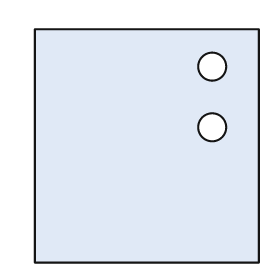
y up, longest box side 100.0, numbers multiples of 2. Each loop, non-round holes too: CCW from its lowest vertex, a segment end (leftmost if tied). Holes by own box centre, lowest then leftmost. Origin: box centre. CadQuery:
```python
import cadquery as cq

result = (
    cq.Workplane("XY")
    .moveTo(-48.0, -50.0)
    .lineTo(48.0, -50.0)
    .lineTo(48.0, 50.0)
    .lineTo(-48.0, 50.0)
    .close()
    .moveTo(28.0, 8.0)
    .circle(6.0)
    .moveTo(28.0, 34.0)
    .circle(6.0)
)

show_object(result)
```